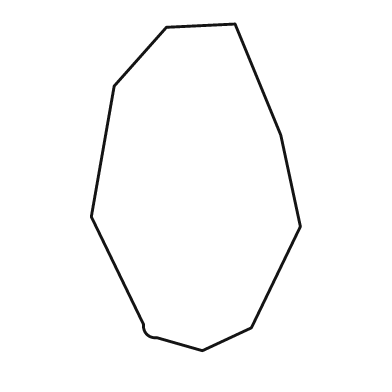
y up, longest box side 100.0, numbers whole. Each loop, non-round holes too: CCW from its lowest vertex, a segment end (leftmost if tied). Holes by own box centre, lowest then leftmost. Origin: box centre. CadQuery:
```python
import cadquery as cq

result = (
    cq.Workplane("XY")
    .moveTo(2.0, -50.0)
    .lineTo(17.0, -43.0)
    .lineTo(32.0, -12.0)
    .lineTo(26.0, 16.0)
    .lineTo(12.0, 50.0)
    .lineTo(-9.0, 49.0)
    .lineTo(-25.0, 31.0)
    .lineTo(-32.0, -9.0)
    .lineTo(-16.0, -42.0)
    .threePointArc((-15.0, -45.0), (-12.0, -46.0))
    .close()
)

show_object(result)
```